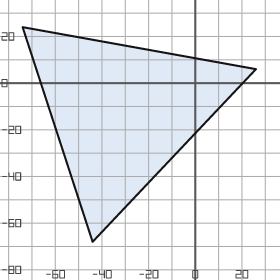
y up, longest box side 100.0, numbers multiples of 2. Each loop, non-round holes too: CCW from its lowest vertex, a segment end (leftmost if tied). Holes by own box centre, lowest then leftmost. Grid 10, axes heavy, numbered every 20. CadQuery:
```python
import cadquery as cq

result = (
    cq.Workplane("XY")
    .moveTo(-44.0, -68.0)
    .lineTo(26.0, 6.0)
    .lineTo(-74.0, 24.0)
    .close()
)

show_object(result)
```